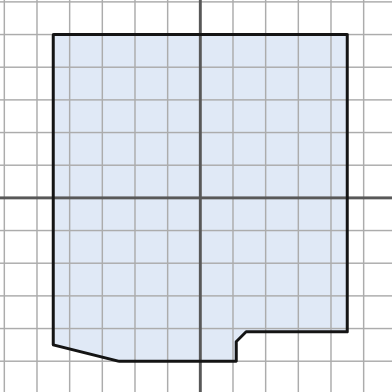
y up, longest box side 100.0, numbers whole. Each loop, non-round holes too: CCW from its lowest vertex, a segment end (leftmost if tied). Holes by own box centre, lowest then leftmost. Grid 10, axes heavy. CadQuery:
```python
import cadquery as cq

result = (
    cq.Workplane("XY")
    .moveTo(-25.0, -50.0)
    .lineTo(11.0, -50.0)
    .lineTo(11.0, -44.0)
    .lineTo(14.0, -41.0)
    .lineTo(45.0, -41.0)
    .lineTo(45.0, 50.0)
    .lineTo(-45.0, 50.0)
    .lineTo(-45.0, -45.0)
    .close()
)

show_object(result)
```